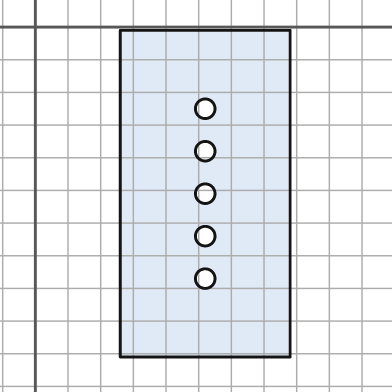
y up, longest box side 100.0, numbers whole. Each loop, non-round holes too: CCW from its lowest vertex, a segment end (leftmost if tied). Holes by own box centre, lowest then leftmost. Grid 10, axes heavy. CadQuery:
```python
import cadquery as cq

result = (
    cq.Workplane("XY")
    .moveTo(26.0, -101.0)
    .lineTo(78.0, -101.0)
    .lineTo(78.0, -1.0)
    .lineTo(26.0, -1.0)
    .close()
    .moveTo(52.0, -77.0)
    .circle(3.0)
    .moveTo(52.0, -64.0)
    .circle(3.0)
    .moveTo(52.0, -51.0)
    .circle(3.0)
    .moveTo(52.0, -38.0)
    .circle(3.0)
    .moveTo(52.0, -25.0)
    .circle(3.0)
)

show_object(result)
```